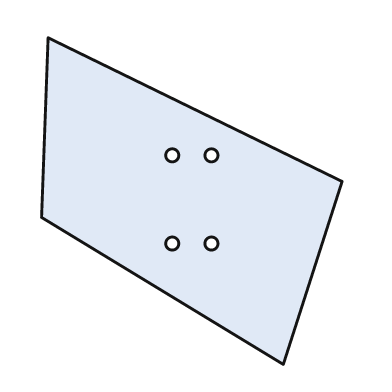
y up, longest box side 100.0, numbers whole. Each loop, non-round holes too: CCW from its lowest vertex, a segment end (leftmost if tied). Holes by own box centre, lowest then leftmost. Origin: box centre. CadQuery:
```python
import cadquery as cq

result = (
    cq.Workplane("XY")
    .moveTo(28.0, -50.0)
    .lineTo(46.0, 6.0)
    .lineTo(-44.0, 50.0)
    .lineTo(-46.0, -5.0)
    .close()
    .moveTo(-6.0, -13.0)
    .circle(2.0)
    .moveTo(6.0, -13.0)
    .circle(2.0)
    .moveTo(-6.0, 14.0)
    .circle(2.0)
    .moveTo(6.0, 14.0)
    .circle(2.0)
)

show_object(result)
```